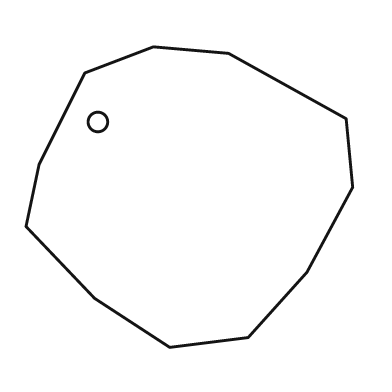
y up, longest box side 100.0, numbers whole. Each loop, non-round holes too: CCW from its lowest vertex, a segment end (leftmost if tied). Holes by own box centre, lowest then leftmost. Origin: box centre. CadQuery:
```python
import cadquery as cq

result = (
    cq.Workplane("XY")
    .moveTo(-6.0, -46.0)
    .lineTo(18.0, -43.0)
    .lineTo(36.0, -23.0)
    .lineTo(50.0, 3.0)
    .lineTo(48.0, 24.0)
    .lineTo(12.0, 44.0)
    .lineTo(-11.0, 46.0)
    .lineTo(-32.0, 38.0)
    .lineTo(-46.0, 10.0)
    .lineTo(-50.0, -9.0)
    .lineTo(-29.0, -31.0)
    .close()
    .moveTo(-28.0, 23.0)
    .circle(3.0)
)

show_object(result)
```